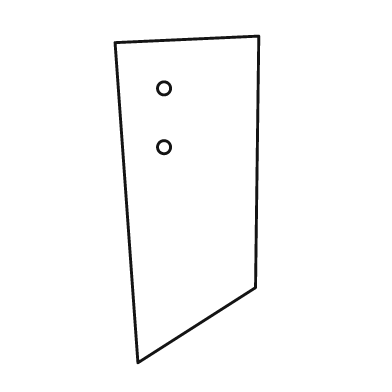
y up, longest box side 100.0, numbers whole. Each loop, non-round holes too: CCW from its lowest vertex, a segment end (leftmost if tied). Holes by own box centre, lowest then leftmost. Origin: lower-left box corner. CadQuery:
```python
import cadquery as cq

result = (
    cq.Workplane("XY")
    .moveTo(7.0, 0.0)
    .lineTo(43.0, 23.0)
    .lineTo(44.0, 100.0)
    .lineTo(0.0, 98.0)
    .close()
    .moveTo(15.0, 66.0)
    .circle(2.0)
    .moveTo(15.0, 84.0)
    .circle(2.0)
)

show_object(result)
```